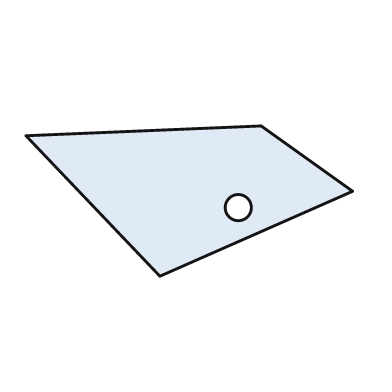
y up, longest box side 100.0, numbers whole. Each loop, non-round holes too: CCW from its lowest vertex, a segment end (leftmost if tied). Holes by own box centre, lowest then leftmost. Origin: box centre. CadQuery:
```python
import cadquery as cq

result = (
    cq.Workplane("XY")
    .moveTo(-9.0, -23.0)
    .lineTo(50.0, 3.0)
    .lineTo(22.0, 23.0)
    .lineTo(-50.0, 20.0)
    .close()
    .moveTo(15.0, -2.0)
    .circle(4.0)
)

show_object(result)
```